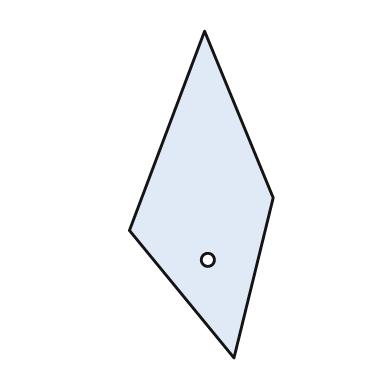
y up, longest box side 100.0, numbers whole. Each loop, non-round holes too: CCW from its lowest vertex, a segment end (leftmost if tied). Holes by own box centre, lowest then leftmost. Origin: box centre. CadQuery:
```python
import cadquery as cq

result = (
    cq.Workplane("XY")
    .moveTo(10.0, -50.0)
    .lineTo(22.0, -1.0)
    .lineTo(1.0, 50.0)
    .lineTo(-22.0, -11.0)
    .close()
    .moveTo(2.0, -20.0)
    .circle(2.0)
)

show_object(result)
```